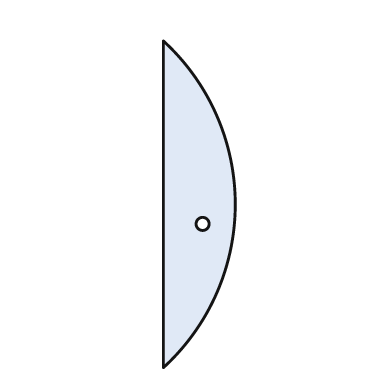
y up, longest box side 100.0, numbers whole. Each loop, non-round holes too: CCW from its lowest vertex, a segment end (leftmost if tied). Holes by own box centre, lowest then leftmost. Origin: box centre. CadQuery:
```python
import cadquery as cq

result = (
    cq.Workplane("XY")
    .moveTo(-11.0, -50.0)
    .threePointArc((11.0, 0.0), (-11.0, 50.0))
    .close()
    .moveTo(1.0, -6.0)
    .circle(2.0)
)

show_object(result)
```